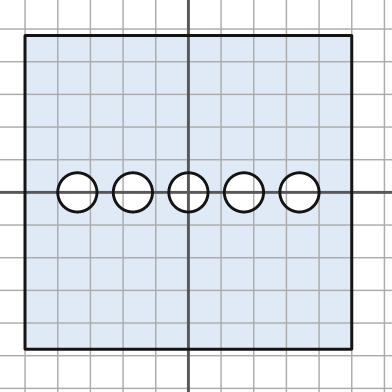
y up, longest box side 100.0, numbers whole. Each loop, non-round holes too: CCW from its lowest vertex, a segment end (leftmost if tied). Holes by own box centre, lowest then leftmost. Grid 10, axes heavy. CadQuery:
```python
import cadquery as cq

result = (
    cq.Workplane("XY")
    .moveTo(-50.0, -48.0)
    .lineTo(50.0, -48.0)
    .lineTo(50.0, 48.0)
    .lineTo(-50.0, 48.0)
    .close()
    .moveTo(-34.0, 0.0)
    .circle(6.0)
    .moveTo(-17.0, 0.0)
    .circle(6.0)
    .moveTo(0.0, 0.0)
    .circle(6.0)
    .moveTo(17.0, 0.0)
    .circle(6.0)
    .moveTo(34.0, 0.0)
    .circle(6.0)
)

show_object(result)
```